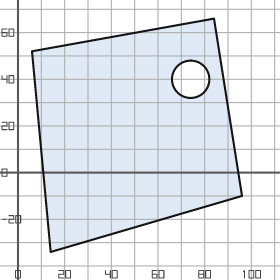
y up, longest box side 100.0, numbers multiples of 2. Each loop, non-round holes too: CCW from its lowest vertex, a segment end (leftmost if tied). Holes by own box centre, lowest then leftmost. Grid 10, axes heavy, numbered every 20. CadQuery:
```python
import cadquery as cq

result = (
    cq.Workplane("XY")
    .moveTo(14.0, -34.0)
    .lineTo(96.0, -10.0)
    .lineTo(84.0, 66.0)
    .lineTo(6.0, 52.0)
    .close()
    .moveTo(74.0, 40.0)
    .circle(8.0)
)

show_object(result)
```